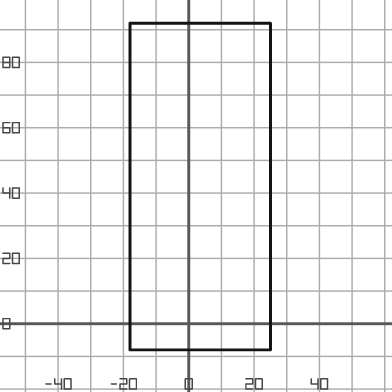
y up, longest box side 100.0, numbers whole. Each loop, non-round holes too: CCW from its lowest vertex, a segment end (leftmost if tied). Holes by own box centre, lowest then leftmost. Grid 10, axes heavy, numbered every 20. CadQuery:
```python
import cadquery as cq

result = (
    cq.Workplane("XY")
    .moveTo(-18.0, -8.0)
    .lineTo(25.0, -8.0)
    .lineTo(25.0, 92.0)
    .lineTo(-18.0, 92.0)
    .close()
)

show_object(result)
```